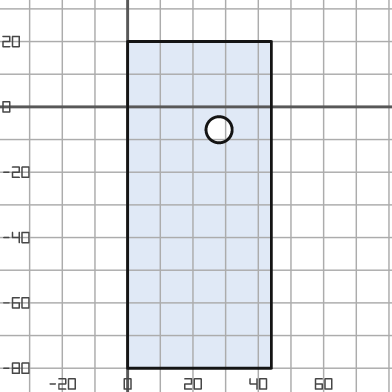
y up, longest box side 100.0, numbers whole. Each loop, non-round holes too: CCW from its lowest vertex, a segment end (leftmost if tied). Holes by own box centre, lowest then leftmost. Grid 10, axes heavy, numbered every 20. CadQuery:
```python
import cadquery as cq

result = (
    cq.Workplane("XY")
    .moveTo(0.0, -80.0)
    .lineTo(44.0, -80.0)
    .lineTo(44.0, 20.0)
    .lineTo(0.0, 20.0)
    .close()
    .moveTo(28.0, -7.0)
    .circle(4.0)
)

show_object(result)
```